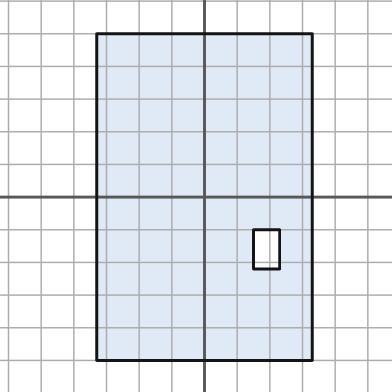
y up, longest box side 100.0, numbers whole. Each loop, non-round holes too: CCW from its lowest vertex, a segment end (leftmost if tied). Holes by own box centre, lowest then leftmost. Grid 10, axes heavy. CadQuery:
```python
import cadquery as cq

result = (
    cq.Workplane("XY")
    .moveTo(-33.0, -50.0)
    .lineTo(33.0, -50.0)
    .lineTo(33.0, 50.0)
    .lineTo(-33.0, 50.0)
    .close()
    .moveTo(15.0, -22.0)
    .lineTo(23.0, -22.0)
    .lineTo(23.0, -10.0)
    .lineTo(15.0, -10.0)
    .close()
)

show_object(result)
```